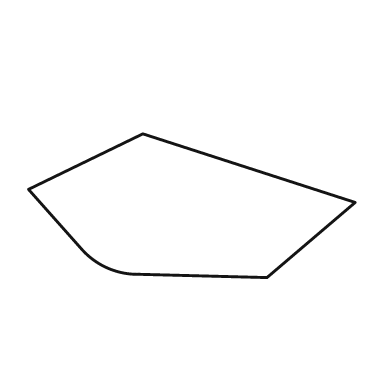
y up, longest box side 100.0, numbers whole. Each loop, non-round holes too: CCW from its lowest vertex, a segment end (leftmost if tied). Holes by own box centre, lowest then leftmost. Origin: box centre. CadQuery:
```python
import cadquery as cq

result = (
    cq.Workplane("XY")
    .moveTo(23.0, -22.0)
    .lineTo(50.0, 1.0)
    .lineTo(-15.0, 22.0)
    .lineTo(-50.0, 5.0)
    .lineTo(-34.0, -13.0)
    .threePointArc((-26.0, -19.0), (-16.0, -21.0))
    .close()
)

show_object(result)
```